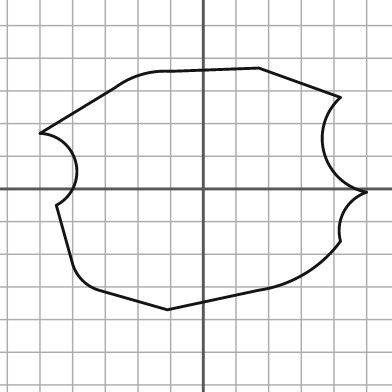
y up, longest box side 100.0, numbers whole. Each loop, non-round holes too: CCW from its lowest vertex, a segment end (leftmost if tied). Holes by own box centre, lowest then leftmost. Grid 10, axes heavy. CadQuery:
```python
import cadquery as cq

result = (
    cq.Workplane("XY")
    .moveTo(-11.0, -37.0)
    .lineTo(17.0, -31.0)
    .threePointArc((31.0, -26.0), (42.0, -16.0))
    .threePointArc((43.0, -7.0), (50.0, -1.0))
    .threePointArc((37.0, 11.0), (42.0, 28.0))
    .lineTo(17.0, 37.0)
    .lineTo(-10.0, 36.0)
    .threePointArc((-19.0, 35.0), (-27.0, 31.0))
    .lineTo(-50.0, 17.0)
    .threePointArc((-39.0, 8.0), (-45.0, -5.0))
    .lineTo(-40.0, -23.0)
    .threePointArc((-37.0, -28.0), (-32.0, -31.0))
    .close()
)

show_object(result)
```